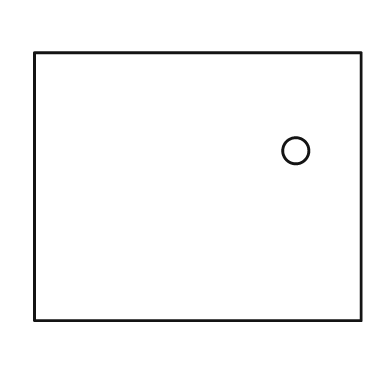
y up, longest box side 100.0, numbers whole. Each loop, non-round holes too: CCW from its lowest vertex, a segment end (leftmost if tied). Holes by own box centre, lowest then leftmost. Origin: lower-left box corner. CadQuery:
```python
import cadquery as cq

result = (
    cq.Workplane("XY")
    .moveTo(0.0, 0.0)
    .lineTo(100.0, 0.0)
    .lineTo(100.0, 82.0)
    .lineTo(0.0, 82.0)
    .close()
    .moveTo(80.0, 52.0)
    .circle(4.0)
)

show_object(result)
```